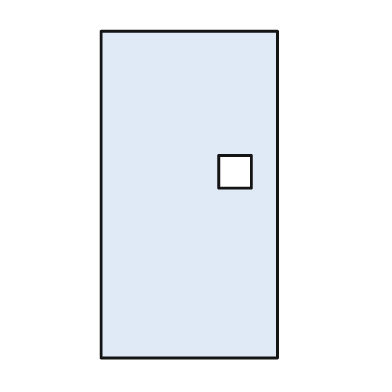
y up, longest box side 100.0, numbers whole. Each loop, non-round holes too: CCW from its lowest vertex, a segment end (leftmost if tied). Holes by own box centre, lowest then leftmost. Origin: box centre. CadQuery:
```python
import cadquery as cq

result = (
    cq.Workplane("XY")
    .moveTo(-27.0, -50.0)
    .lineTo(27.0, -50.0)
    .lineTo(27.0, 50.0)
    .lineTo(-27.0, 50.0)
    .close()
    .moveTo(9.0, 2.0)
    .lineTo(19.0, 2.0)
    .lineTo(19.0, 12.0)
    .lineTo(9.0, 12.0)
    .close()
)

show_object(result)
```